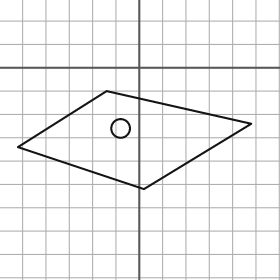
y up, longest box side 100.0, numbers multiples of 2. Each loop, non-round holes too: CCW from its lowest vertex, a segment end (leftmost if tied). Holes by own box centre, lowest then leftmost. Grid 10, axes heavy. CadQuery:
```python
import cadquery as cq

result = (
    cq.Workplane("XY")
    .moveTo(2.0, -52.0)
    .lineTo(48.0, -24.0)
    .lineTo(-14.0, -10.0)
    .lineTo(-52.0, -34.0)
    .close()
    .moveTo(-8.0, -26.0)
    .circle(4.0)
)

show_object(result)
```